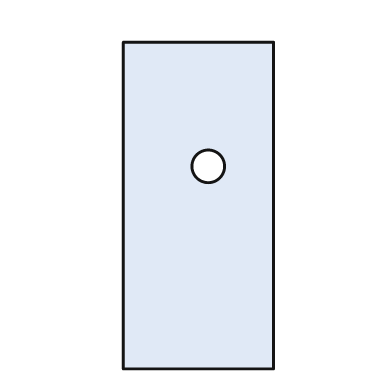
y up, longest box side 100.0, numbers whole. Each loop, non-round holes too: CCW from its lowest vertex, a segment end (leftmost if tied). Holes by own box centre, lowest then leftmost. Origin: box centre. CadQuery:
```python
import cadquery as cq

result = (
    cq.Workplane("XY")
    .moveTo(-23.0, -50.0)
    .lineTo(23.0, -50.0)
    .lineTo(23.0, 50.0)
    .lineTo(-23.0, 50.0)
    .close()
    .moveTo(3.0, 12.0)
    .circle(5.0)
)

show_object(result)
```